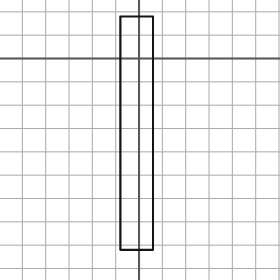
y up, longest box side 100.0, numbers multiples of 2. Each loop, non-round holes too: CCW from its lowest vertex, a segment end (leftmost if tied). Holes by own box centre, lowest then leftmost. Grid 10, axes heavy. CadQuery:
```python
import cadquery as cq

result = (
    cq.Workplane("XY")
    .moveTo(-8.0, -82.0)
    .lineTo(6.0, -82.0)
    .lineTo(6.0, 18.0)
    .lineTo(-8.0, 18.0)
    .close()
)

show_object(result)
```